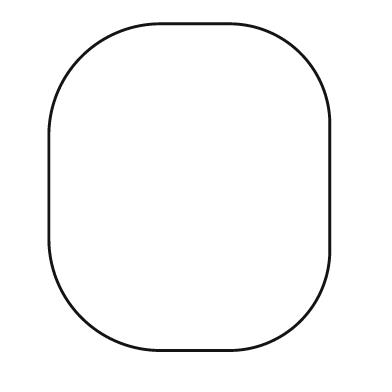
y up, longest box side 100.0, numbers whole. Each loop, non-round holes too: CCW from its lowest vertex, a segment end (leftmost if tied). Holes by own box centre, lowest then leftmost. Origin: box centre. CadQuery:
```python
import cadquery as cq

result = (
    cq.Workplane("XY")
    .moveTo(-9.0, -50.0)
    .lineTo(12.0, -50.0)
    .threePointArc((34.0, -41.0), (43.0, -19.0))
    .lineTo(43.0, 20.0)
    .threePointArc((34.0, 41.0), (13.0, 50.0))
    .lineTo(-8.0, 50.0)
    .threePointArc((-33.0, 40.0), (-43.0, 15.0))
    .lineTo(-43.0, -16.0)
    .threePointArc((-33.0, -40.0), (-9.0, -50.0))
    .close()
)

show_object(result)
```